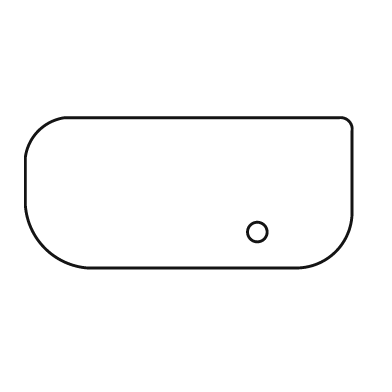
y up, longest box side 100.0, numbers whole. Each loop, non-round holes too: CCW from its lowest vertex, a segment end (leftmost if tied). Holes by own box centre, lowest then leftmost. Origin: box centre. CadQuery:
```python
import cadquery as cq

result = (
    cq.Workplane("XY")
    .moveTo(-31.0, -23.0)
    .lineTo(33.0, -23.0)
    .threePointArc((45.0, -18.0), (50.0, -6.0))
    .lineTo(50.0, 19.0)
    .threePointArc((49.0, 22.0), (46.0, 23.0))
    .lineTo(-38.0, 23.0)
    .threePointArc((-46.0, 19.0), (-50.0, 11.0))
    .lineTo(-50.0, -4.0)
    .threePointArc((-44.0, -17.0), (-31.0, -23.0))
    .close()
    .moveTo(21.0, -12.0)
    .circle(3.0)
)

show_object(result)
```